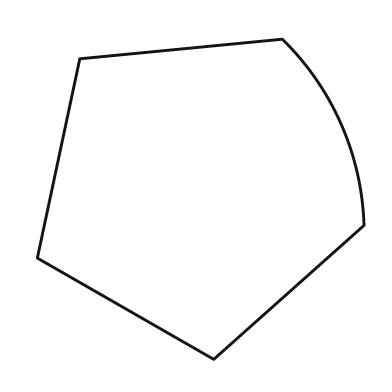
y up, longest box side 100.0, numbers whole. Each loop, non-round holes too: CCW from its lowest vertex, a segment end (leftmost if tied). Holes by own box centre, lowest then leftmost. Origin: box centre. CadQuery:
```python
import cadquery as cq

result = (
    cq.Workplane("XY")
    .moveTo(4.0, -49.0)
    .lineTo(50.0, -8.0)
    .threePointArc((43.0, 23.0), (25.0, 49.0))
    .lineTo(-37.0, 43.0)
    .lineTo(-50.0, -18.0)
    .close()
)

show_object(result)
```